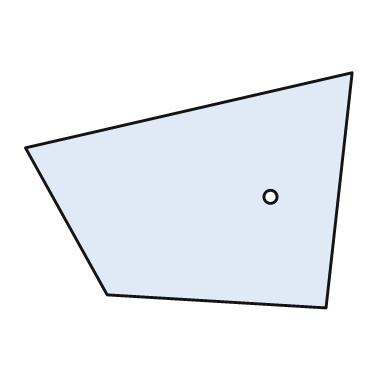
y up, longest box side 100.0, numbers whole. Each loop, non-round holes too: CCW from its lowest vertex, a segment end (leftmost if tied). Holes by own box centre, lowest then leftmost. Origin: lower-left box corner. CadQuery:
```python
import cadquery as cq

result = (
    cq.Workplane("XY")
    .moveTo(92.0, 0.0)
    .lineTo(100.0, 72.0)
    .lineTo(0.0, 49.0)
    .lineTo(25.0, 4.0)
    .close()
    .moveTo(75.0, 34.0)
    .circle(2.0)
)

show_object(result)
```